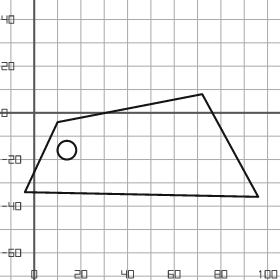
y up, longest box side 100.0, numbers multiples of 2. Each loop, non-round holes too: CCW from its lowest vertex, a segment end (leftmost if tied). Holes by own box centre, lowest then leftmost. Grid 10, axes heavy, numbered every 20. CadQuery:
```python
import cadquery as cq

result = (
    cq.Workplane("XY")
    .moveTo(96.0, -36.0)
    .lineTo(72.0, 8.0)
    .lineTo(10.0, -4.0)
    .lineTo(-4.0, -34.0)
    .close()
    .moveTo(14.0, -16.0)
    .circle(4.0)
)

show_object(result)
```